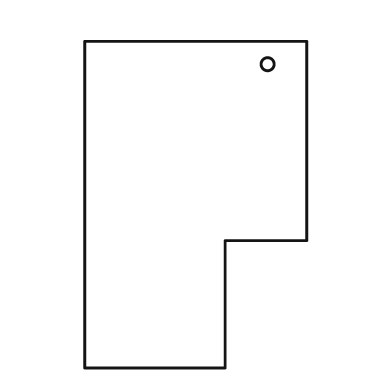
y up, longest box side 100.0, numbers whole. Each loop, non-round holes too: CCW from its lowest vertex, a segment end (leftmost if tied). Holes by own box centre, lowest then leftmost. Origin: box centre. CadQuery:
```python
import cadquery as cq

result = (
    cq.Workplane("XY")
    .moveTo(-34.0, -50.0)
    .lineTo(9.0, -50.0)
    .lineTo(9.0, -11.0)
    .lineTo(34.0, -11.0)
    .lineTo(34.0, 50.0)
    .lineTo(-34.0, 50.0)
    .close()
    .moveTo(22.0, 43.0)
    .circle(2.0)
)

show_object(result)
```